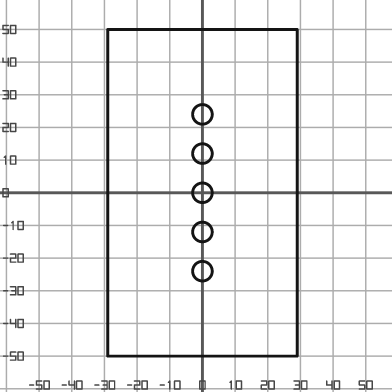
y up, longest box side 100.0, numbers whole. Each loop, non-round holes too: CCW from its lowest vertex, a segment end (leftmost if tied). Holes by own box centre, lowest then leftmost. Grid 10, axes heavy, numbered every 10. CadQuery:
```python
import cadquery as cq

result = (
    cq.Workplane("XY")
    .moveTo(-29.0, -50.0)
    .lineTo(29.0, -50.0)
    .lineTo(29.0, 50.0)
    .lineTo(-29.0, 50.0)
    .close()
    .moveTo(0.0, -24.0)
    .circle(3.0)
    .moveTo(0.0, -12.0)
    .circle(3.0)
    .moveTo(0.0, 0.0)
    .circle(3.0)
    .moveTo(0.0, 12.0)
    .circle(3.0)
    .moveTo(0.0, 24.0)
    .circle(3.0)
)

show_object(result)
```